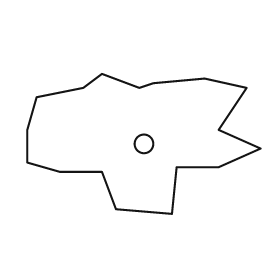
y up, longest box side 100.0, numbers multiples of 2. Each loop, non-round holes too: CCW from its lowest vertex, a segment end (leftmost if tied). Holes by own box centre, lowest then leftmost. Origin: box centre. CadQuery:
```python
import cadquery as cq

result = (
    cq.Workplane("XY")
    .moveTo(12.0, -30.0)
    .lineTo(14.0, -10.0)
    .lineTo(32.0, -10.0)
    .lineTo(50.0, -2.0)
    .lineTo(32.0, 6.0)
    .lineTo(44.0, 24.0)
    .lineTo(26.0, 28.0)
    .lineTo(4.0, 26.0)
    .lineTo(-2.0, 24.0)
    .lineTo(-18.0, 30.0)
    .lineTo(-26.0, 24.0)
    .lineTo(-46.0, 20.0)
    .lineTo(-50.0, 6.0)
    .lineTo(-50.0, -8.0)
    .lineTo(-36.0, -12.0)
    .lineTo(-18.0, -12.0)
    .lineTo(-12.0, -28.0)
    .close()
    .moveTo(0.0, 0.0)
    .circle(4.0)
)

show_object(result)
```